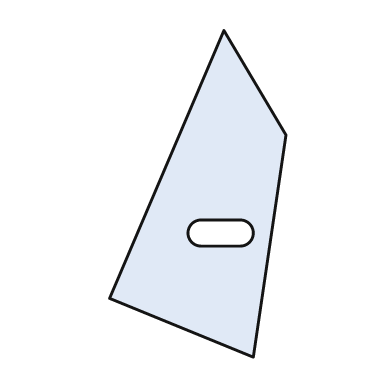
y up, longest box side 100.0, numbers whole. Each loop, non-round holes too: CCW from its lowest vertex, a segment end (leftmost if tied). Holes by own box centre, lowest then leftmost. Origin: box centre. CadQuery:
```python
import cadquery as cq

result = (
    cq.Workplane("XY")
    .moveTo(17.0, -50.0)
    .lineTo(27.0, 18.0)
    .lineTo(8.0, 50.0)
    .lineTo(-27.0, -32.0)
    .close()
    .moveTo(1.0, -16.0)
    .lineTo(13.0, -16.0)
    .threePointArc((17.0, -12.0), (13.0, -8.0))
    .lineTo(1.0, -8.0)
    .threePointArc((-3.0, -12.0), (1.0, -16.0))
    .close()
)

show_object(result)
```